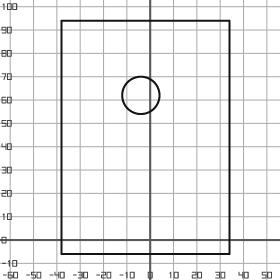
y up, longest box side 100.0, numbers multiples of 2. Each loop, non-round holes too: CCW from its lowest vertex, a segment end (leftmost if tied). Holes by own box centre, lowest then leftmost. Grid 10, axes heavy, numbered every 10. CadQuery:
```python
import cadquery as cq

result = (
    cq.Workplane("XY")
    .moveTo(-38.0, -6.0)
    .lineTo(34.0, -6.0)
    .lineTo(34.0, 94.0)
    .lineTo(-38.0, 94.0)
    .close()
    .moveTo(-4.0, 62.0)
    .circle(8.0)
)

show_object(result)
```